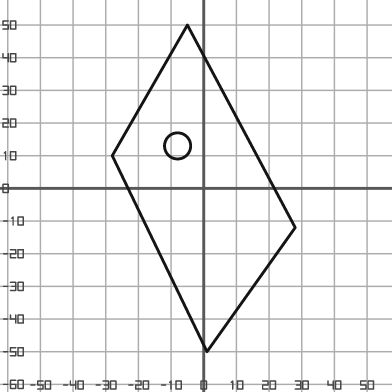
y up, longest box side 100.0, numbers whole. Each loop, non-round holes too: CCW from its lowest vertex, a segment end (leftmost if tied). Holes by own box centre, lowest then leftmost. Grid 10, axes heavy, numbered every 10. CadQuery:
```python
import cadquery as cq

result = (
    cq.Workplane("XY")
    .moveTo(1.0, -50.0)
    .lineTo(28.0, -12.0)
    .lineTo(-5.0, 50.0)
    .lineTo(-28.0, 10.0)
    .close()
    .moveTo(-8.0, 13.0)
    .circle(4.0)
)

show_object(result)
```